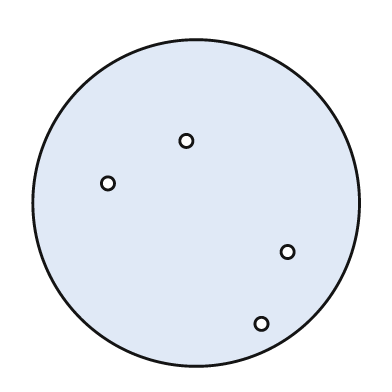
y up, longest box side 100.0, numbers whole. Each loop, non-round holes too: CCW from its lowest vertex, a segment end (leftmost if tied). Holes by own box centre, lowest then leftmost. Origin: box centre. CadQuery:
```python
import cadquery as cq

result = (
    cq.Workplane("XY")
    .moveTo(0.0, 0.0)
    .circle(50.0)
    .moveTo(20.0, -37.0)
    .circle(2.0)
    .moveTo(28.0, -15.0)
    .circle(2.0)
    .moveTo(-27.0, 6.0)
    .circle(2.0)
    .moveTo(-3.0, 19.0)
    .circle(2.0)
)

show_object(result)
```